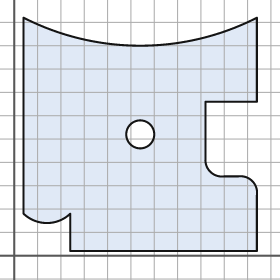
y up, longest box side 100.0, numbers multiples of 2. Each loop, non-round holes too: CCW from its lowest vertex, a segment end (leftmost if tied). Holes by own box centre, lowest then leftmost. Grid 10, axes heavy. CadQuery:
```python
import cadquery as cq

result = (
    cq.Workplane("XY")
    .moveTo(24.0, 2.0)
    .lineTo(104.0, 2.0)
    .lineTo(104.0, 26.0)
    .threePointArc((102.0, 32.0), (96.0, 34.0))
    .lineTo(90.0, 34.0)
    .threePointArc((84.0, 36.0), (82.0, 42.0))
    .lineTo(82.0, 66.0)
    .lineTo(104.0, 66.0)
    .lineTo(104.0, 102.0)
    .threePointArc((54.0, 90.0), (4.0, 102.0))
    .lineTo(4.0, 18.0)
    .threePointArc((14.0, 14.0), (24.0, 18.0))
    .close()
    .moveTo(54.0, 52.0)
    .circle(6.0)
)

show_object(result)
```